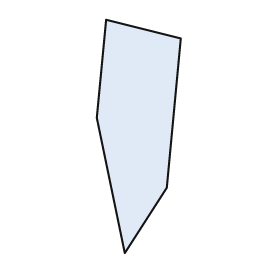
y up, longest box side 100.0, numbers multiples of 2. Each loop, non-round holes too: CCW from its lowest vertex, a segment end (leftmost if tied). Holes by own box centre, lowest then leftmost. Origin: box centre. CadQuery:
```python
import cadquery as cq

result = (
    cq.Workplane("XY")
    .moveTo(-6.0, -50.0)
    .lineTo(12.0, -22.0)
    .lineTo(18.0, 42.0)
    .lineTo(-14.0, 50.0)
    .lineTo(-18.0, 8.0)
    .close()
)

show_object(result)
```